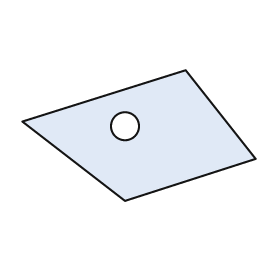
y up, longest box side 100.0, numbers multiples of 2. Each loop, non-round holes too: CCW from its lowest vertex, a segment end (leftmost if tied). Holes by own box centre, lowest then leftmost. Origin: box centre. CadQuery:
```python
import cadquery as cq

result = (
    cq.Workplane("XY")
    .moveTo(-6.0, -28.0)
    .lineTo(50.0, -10.0)
    .lineTo(20.0, 28.0)
    .lineTo(-50.0, 6.0)
    .close()
    .moveTo(-6.0, 4.0)
    .circle(6.0)
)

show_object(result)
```